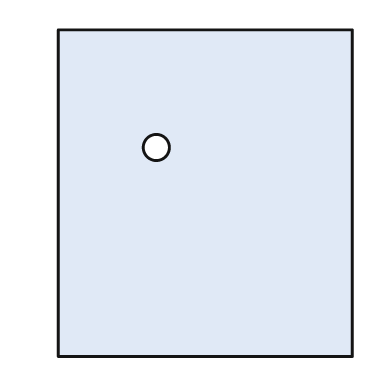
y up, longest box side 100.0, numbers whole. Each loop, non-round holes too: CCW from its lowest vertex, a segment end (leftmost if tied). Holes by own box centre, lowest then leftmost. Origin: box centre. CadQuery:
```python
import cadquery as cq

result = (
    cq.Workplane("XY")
    .moveTo(-45.0, -50.0)
    .lineTo(45.0, -50.0)
    .lineTo(45.0, 50.0)
    .lineTo(-45.0, 50.0)
    .close()
    .moveTo(-15.0, 14.0)
    .circle(4.0)
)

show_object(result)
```